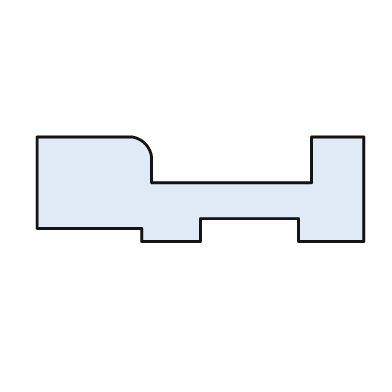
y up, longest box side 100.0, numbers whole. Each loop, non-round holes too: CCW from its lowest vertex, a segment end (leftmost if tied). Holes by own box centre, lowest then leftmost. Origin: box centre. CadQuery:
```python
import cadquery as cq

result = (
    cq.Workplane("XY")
    .moveTo(-18.0, -16.0)
    .lineTo(0.0, -16.0)
    .lineTo(0.0, -9.0)
    .lineTo(30.0, -9.0)
    .lineTo(30.0, -16.0)
    .lineTo(50.0, -16.0)
    .lineTo(50.0, 16.0)
    .lineTo(34.0, 16.0)
    .lineTo(34.0, 2.0)
    .lineTo(-15.0, 2.0)
    .lineTo(-15.0, 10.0)
    .threePointArc((-17.0, 14.0), (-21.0, 16.0))
    .lineTo(-50.0, 16.0)
    .lineTo(-50.0, -12.0)
    .lineTo(-18.0, -12.0)
    .close()
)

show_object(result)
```